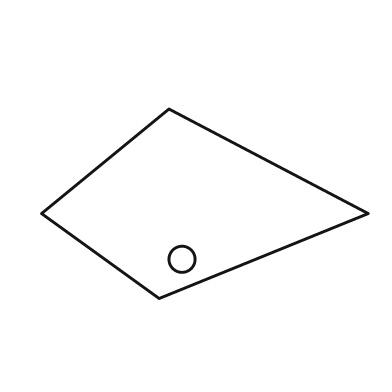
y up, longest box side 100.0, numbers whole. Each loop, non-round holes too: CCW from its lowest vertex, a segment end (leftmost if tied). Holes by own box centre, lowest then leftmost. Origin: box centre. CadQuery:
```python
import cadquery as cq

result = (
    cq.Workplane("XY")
    .moveTo(-14.0, -29.0)
    .lineTo(50.0, -3.0)
    .lineTo(-11.0, 29.0)
    .lineTo(-50.0, -3.0)
    .close()
    .moveTo(-7.0, -17.0)
    .circle(4.0)
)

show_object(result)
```